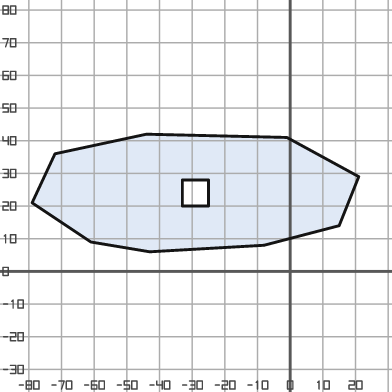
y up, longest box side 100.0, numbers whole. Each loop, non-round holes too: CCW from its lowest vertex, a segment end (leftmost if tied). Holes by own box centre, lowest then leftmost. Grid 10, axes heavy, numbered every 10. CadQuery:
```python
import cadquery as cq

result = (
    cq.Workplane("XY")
    .moveTo(-43.0, 6.0)
    .lineTo(-8.0, 8.0)
    .lineTo(15.0, 14.0)
    .lineTo(21.0, 29.0)
    .lineTo(-1.0, 41.0)
    .lineTo(-44.0, 42.0)
    .lineTo(-72.0, 36.0)
    .lineTo(-79.0, 21.0)
    .lineTo(-61.0, 9.0)
    .close()
    .moveTo(-33.0, 20.0)
    .lineTo(-25.0, 20.0)
    .lineTo(-25.0, 28.0)
    .lineTo(-33.0, 28.0)
    .close()
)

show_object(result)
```